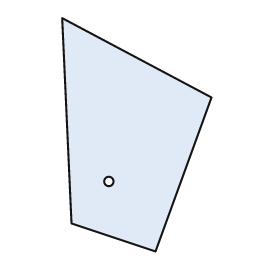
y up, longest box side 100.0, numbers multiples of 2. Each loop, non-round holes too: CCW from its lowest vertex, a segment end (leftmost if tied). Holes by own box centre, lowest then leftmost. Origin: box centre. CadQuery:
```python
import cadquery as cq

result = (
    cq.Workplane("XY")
    .moveTo(8.0, -50.0)
    .lineTo(32.0, 16.0)
    .lineTo(-32.0, 50.0)
    .lineTo(-28.0, -38.0)
    .close()
    .moveTo(-12.0, -20.0)
    .circle(2.0)
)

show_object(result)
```